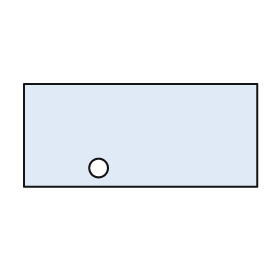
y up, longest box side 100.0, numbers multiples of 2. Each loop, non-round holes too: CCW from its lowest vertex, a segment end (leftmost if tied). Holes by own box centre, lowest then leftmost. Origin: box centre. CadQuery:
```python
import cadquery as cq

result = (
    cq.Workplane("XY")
    .moveTo(-50.0, -22.0)
    .lineTo(50.0, -22.0)
    .lineTo(50.0, 22.0)
    .lineTo(-50.0, 22.0)
    .close()
    .moveTo(-18.0, -14.0)
    .circle(4.0)
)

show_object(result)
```